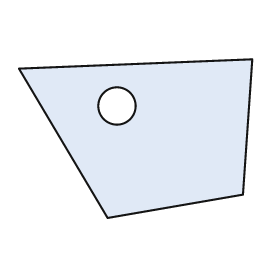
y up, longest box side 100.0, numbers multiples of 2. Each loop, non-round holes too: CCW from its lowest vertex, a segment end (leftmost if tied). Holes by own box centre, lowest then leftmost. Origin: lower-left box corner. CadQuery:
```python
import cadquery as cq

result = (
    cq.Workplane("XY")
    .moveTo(38.0, 0.0)
    .lineTo(96.0, 10.0)
    .lineTo(100.0, 68.0)
    .lineTo(0.0, 64.0)
    .close()
    .moveTo(42.0, 48.0)
    .circle(8.0)
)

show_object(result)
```